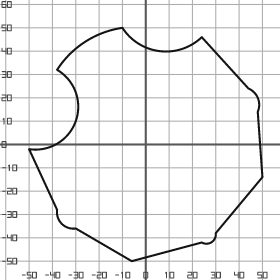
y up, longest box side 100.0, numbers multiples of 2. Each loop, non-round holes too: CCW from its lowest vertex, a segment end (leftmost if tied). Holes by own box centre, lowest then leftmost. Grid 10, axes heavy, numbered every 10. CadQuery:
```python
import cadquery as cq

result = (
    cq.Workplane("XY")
    .moveTo(-6.0, -50.0)
    .lineTo(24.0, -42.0)
    .threePointArc((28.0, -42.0), (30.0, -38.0))
    .lineTo(50.0, -14.0)
    .lineTo(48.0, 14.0)
    .threePointArc((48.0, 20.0), (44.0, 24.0))
    .lineTo(24.0, 46.0)
    .threePointArc((6.0, 40.0), (-10.0, 50.0))
    .threePointArc((-26.0, 44.0), (-38.0, 32.0))
    .threePointArc((-30.0, 10.0), (-50.0, -2.0))
    .lineTo(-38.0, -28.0)
    .threePointArc((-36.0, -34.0), (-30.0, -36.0))
    .close()
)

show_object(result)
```